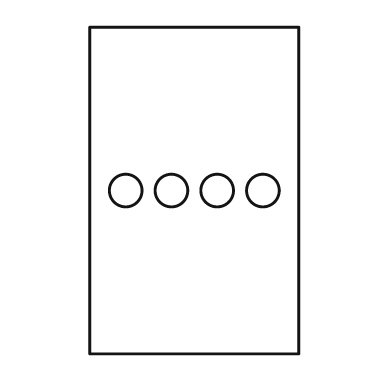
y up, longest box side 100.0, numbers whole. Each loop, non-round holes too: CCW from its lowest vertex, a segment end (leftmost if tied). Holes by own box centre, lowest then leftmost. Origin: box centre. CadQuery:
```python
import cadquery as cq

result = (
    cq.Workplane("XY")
    .moveTo(-32.0, -50.0)
    .lineTo(32.0, -50.0)
    .lineTo(32.0, 50.0)
    .lineTo(-32.0, 50.0)
    .close()
    .moveTo(-21.0, 0.0)
    .circle(5.0)
    .moveTo(-7.0, 0.0)
    .circle(5.0)
    .moveTo(7.0, 0.0)
    .circle(5.0)
    .moveTo(21.0, 0.0)
    .circle(5.0)
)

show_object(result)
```